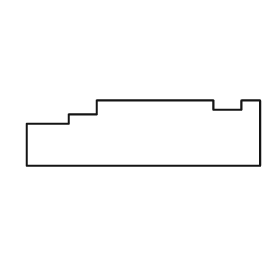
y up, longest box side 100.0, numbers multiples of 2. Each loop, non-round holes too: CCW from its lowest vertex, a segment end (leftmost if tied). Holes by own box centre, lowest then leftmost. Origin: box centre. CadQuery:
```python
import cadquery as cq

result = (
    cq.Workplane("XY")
    .moveTo(-50.0, -14.0)
    .lineTo(50.0, -14.0)
    .lineTo(50.0, 14.0)
    .lineTo(42.0, 14.0)
    .lineTo(42.0, 10.0)
    .lineTo(30.0, 10.0)
    .lineTo(30.0, 14.0)
    .lineTo(-20.0, 14.0)
    .lineTo(-20.0, 8.0)
    .lineTo(-32.0, 8.0)
    .lineTo(-32.0, 4.0)
    .lineTo(-50.0, 4.0)
    .close()
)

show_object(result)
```